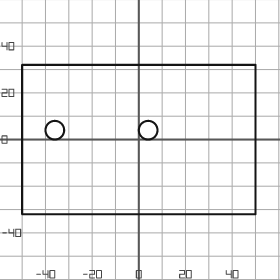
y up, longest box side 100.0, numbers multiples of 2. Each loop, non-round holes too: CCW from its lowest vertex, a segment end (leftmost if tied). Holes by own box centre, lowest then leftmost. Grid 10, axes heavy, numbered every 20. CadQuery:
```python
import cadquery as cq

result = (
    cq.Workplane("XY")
    .moveTo(-50.0, -32.0)
    .lineTo(50.0, -32.0)
    .lineTo(50.0, 32.0)
    .lineTo(-50.0, 32.0)
    .close()
    .moveTo(-36.0, 4.0)
    .circle(4.0)
    .moveTo(4.0, 4.0)
    .circle(4.0)
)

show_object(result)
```